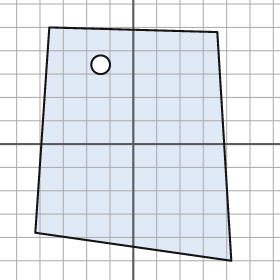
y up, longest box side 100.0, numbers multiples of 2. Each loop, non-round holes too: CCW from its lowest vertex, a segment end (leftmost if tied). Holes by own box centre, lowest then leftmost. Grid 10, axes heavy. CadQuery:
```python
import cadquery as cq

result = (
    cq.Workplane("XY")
    .moveTo(42.0, -50.0)
    .lineTo(36.0, 48.0)
    .lineTo(-36.0, 50.0)
    .lineTo(-42.0, -38.0)
    .close()
    .moveTo(-14.0, 34.0)
    .circle(4.0)
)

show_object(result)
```